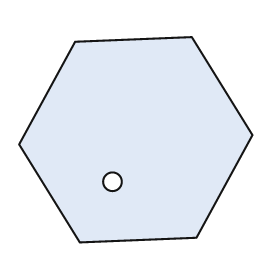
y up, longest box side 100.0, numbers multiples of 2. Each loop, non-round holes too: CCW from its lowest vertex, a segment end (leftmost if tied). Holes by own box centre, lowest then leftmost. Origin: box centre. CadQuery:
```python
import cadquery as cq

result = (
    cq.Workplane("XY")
    .moveTo(-24.0, -44.0)
    .lineTo(26.0, -42.0)
    .lineTo(50.0, 2.0)
    .lineTo(24.0, 44.0)
    .lineTo(-26.0, 42.0)
    .lineTo(-50.0, -2.0)
    .close()
    .moveTo(-10.0, -18.0)
    .circle(4.0)
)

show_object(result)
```